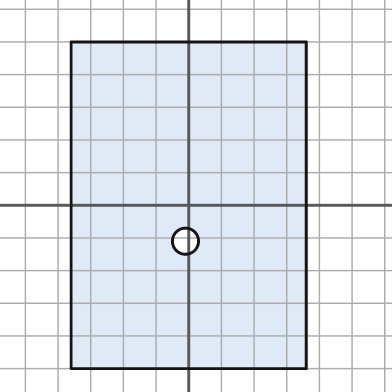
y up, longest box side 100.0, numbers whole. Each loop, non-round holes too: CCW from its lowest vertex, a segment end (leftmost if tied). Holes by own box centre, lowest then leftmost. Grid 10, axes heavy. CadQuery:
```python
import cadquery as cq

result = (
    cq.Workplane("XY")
    .moveTo(-36.0, -50.0)
    .lineTo(36.0, -50.0)
    .lineTo(36.0, 50.0)
    .lineTo(-36.0, 50.0)
    .close()
    .moveTo(-1.0, -11.0)
    .circle(4.0)
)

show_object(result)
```